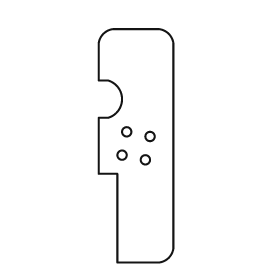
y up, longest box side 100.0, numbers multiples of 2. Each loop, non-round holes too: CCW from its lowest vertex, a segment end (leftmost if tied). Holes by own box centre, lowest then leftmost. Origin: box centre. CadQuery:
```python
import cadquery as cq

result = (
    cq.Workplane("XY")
    .moveTo(-8.0, -50.0)
    .lineTo(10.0, -50.0)
    .threePointArc((14.0, -48.0), (16.0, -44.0))
    .lineTo(16.0, 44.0)
    .threePointArc((14.0, 48.0), (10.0, 50.0))
    .lineTo(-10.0, 50.0)
    .threePointArc((-14.0, 48.0), (-16.0, 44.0))
    .lineTo(-16.0, 28.0)
    .lineTo(-12.0, 28.0)
    .threePointArc((-6.0, 20.0), (-12.0, 12.0))
    .lineTo(-16.0, 12.0)
    .lineTo(-16.0, -12.0)
    .lineTo(-8.0, -12.0)
    .close()
    .moveTo(4.0, -6.0)
    .circle(2.0)
    .moveTo(-6.0, -4.0)
    .circle(2.0)
    .moveTo(6.0, 4.0)
    .circle(2.0)
    .moveTo(-4.0, 6.0)
    .circle(2.0)
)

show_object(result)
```